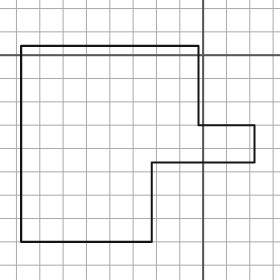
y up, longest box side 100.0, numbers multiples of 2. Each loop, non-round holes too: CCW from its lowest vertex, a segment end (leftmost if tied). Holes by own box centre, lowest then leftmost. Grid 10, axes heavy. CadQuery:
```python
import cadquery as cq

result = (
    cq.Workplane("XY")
    .moveTo(-78.0, -80.0)
    .lineTo(-22.0, -80.0)
    .lineTo(-22.0, -46.0)
    .lineTo(22.0, -46.0)
    .lineTo(22.0, -30.0)
    .lineTo(-2.0, -30.0)
    .lineTo(-2.0, 4.0)
    .lineTo(-78.0, 4.0)
    .close()
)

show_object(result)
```